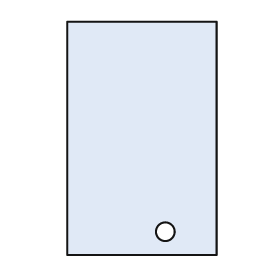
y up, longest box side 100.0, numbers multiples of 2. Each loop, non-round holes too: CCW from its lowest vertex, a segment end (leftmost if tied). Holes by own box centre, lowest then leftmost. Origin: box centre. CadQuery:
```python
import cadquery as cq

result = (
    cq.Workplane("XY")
    .moveTo(-32.0, -50.0)
    .lineTo(32.0, -50.0)
    .lineTo(32.0, 50.0)
    .lineTo(-32.0, 50.0)
    .close()
    .moveTo(10.0, -40.0)
    .circle(4.0)
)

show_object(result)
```